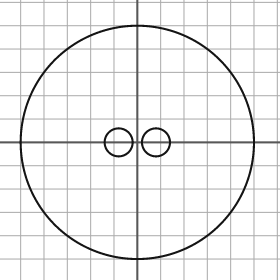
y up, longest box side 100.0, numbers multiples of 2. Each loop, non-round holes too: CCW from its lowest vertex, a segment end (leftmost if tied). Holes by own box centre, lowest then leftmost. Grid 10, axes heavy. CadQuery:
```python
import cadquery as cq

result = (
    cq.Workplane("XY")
    .moveTo(0.0, 0.0)
    .circle(50.0)
    .moveTo(-8.0, 0.0)
    .circle(6.0)
    .moveTo(8.0, 0.0)
    .circle(6.0)
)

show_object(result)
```